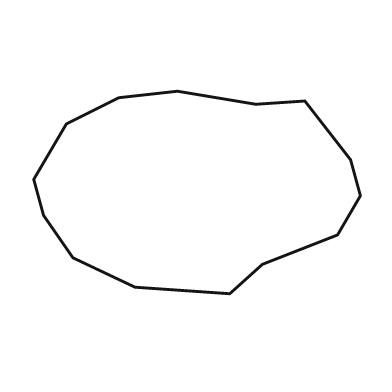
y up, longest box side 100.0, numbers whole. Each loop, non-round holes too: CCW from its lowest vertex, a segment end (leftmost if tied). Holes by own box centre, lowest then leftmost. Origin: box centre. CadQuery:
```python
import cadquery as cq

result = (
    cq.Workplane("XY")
    .moveTo(10.0, -31.0)
    .lineTo(20.0, -22.0)
    .lineTo(43.0, -13.0)
    .lineTo(50.0, -1.0)
    .lineTo(47.0, 10.0)
    .lineTo(33.0, 28.0)
    .lineTo(18.0, 27.0)
    .lineTo(-6.0, 31.0)
    .lineTo(-24.0, 29.0)
    .lineTo(-40.0, 21.0)
    .lineTo(-50.0, 4.0)
    .lineTo(-47.0, -7.0)
    .lineTo(-38.0, -20.0)
    .lineTo(-19.0, -29.0)
    .close()
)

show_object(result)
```